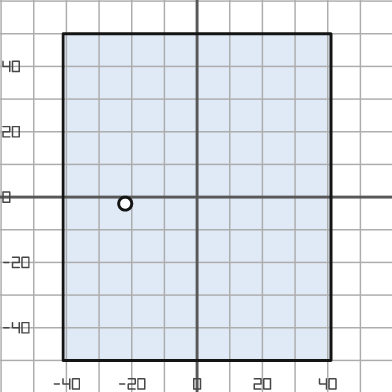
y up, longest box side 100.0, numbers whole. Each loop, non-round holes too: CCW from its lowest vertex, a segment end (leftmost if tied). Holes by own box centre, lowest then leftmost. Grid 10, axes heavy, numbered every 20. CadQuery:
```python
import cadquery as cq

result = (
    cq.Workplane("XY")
    .moveTo(-41.0, -50.0)
    .lineTo(41.0, -50.0)
    .lineTo(41.0, 50.0)
    .lineTo(-41.0, 50.0)
    .close()
    .moveTo(-22.0, -2.0)
    .circle(2.0)
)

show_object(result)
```